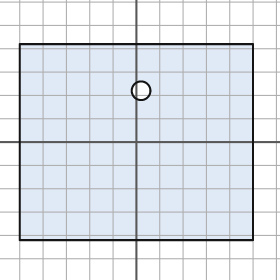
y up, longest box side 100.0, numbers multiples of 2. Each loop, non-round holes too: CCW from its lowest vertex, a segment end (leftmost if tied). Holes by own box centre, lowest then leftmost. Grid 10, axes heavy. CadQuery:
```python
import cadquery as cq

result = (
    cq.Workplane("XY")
    .moveTo(-50.0, -42.0)
    .lineTo(50.0, -42.0)
    .lineTo(50.0, 42.0)
    .lineTo(-50.0, 42.0)
    .close()
    .moveTo(2.0, 22.0)
    .circle(4.0)
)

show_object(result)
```